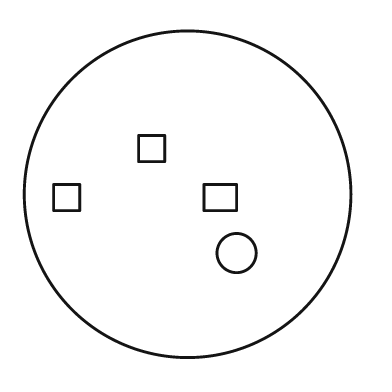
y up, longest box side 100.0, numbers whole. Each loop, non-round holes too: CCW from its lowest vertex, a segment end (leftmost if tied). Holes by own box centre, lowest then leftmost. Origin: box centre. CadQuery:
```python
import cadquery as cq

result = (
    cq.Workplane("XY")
    .moveTo(0.0, 0.0)
    .circle(50.0)
    .moveTo(15.0, -18.0)
    .circle(6.0)
    .moveTo(-41.0, -5.0)
    .lineTo(-33.0, -5.0)
    .lineTo(-33.0, 3.0)
    .lineTo(-41.0, 3.0)
    .close()
    .moveTo(5.0, -5.0)
    .lineTo(15.0, -5.0)
    .lineTo(15.0, 3.0)
    .lineTo(5.0, 3.0)
    .close()
    .moveTo(-15.0, 10.0)
    .lineTo(-7.0, 10.0)
    .lineTo(-7.0, 18.0)
    .lineTo(-15.0, 18.0)
    .close()
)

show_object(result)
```